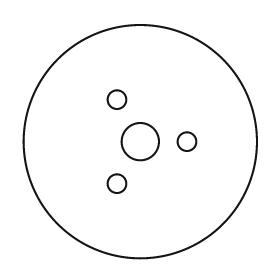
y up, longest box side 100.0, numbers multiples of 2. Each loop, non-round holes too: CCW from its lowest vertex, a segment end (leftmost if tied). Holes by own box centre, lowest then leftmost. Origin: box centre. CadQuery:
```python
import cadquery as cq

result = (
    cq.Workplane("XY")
    .moveTo(0.0, 0.0)
    .circle(50.0)
    .moveTo(-10.0, -18.0)
    .circle(4.0)
    .moveTo(0.0, 0.0)
    .circle(8.0)
    .moveTo(20.0, 0.0)
    .circle(4.0)
    .moveTo(-10.0, 18.0)
    .circle(4.0)
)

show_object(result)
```